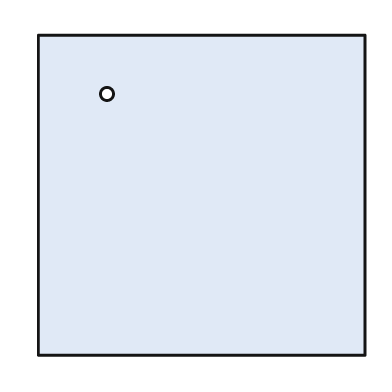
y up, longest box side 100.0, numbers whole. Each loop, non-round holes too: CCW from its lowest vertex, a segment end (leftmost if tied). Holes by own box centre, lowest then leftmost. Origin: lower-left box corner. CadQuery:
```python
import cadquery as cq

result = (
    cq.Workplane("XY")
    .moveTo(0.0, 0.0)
    .lineTo(100.0, 0.0)
    .lineTo(100.0, 98.0)
    .lineTo(0.0, 98.0)
    .close()
    .moveTo(21.0, 80.0)
    .circle(2.0)
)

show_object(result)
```